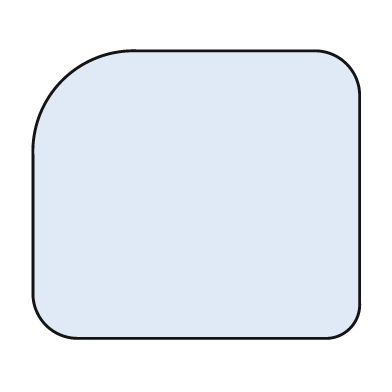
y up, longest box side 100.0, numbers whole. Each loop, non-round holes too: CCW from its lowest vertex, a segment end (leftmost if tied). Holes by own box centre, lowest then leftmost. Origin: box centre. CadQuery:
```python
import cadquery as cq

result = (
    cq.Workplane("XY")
    .moveTo(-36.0, -44.0)
    .lineTo(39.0, -44.0)
    .threePointArc((47.0, -41.0), (50.0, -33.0))
    .lineTo(50.0, 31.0)
    .threePointArc((46.0, 40.0), (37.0, 44.0))
    .lineTo(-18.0, 44.0)
    .threePointArc((-41.0, 35.0), (-50.0, 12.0))
    .lineTo(-50.0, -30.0)
    .threePointArc((-46.0, -40.0), (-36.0, -44.0))
    .close()
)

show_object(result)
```